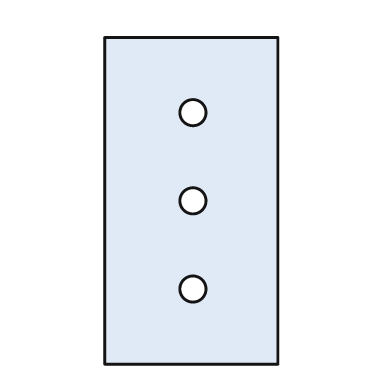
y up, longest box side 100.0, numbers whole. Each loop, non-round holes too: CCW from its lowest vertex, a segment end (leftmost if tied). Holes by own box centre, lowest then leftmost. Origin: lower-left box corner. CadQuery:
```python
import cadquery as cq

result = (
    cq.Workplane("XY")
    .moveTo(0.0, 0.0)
    .lineTo(53.0, 0.0)
    .lineTo(53.0, 100.0)
    .lineTo(0.0, 100.0)
    .close()
    .moveTo(27.0, 23.0)
    .circle(4.0)
    .moveTo(27.0, 50.0)
    .circle(4.0)
    .moveTo(27.0, 77.0)
    .circle(4.0)
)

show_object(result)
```